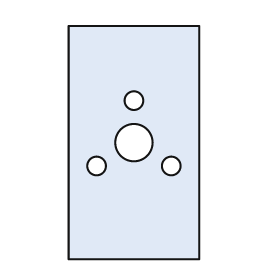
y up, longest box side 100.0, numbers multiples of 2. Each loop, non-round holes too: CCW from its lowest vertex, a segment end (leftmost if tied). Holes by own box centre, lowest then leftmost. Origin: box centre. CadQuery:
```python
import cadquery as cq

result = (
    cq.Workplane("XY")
    .moveTo(-28.0, -50.0)
    .lineTo(28.0, -50.0)
    .lineTo(28.0, 50.0)
    .lineTo(-28.0, 50.0)
    .close()
    .moveTo(-16.0, -10.0)
    .circle(4.0)
    .moveTo(16.0, -10.0)
    .circle(4.0)
    .moveTo(0.0, 0.0)
    .circle(8.0)
    .moveTo(0.0, 18.0)
    .circle(4.0)
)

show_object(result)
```